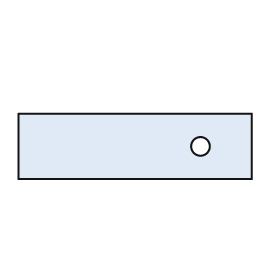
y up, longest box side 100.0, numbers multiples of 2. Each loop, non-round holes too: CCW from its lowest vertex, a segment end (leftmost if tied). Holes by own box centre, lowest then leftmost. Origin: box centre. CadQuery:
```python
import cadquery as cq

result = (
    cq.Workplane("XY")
    .moveTo(-50.0, -14.0)
    .lineTo(50.0, -14.0)
    .lineTo(50.0, 14.0)
    .lineTo(-50.0, 14.0)
    .close()
    .moveTo(28.0, 0.0)
    .circle(4.0)
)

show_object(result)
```